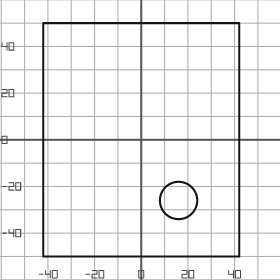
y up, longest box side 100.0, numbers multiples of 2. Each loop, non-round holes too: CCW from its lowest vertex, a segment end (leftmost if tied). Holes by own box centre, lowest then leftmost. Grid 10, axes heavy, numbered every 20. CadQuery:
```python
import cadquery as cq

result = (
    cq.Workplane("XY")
    .moveTo(-42.0, -50.0)
    .lineTo(42.0, -50.0)
    .lineTo(42.0, 50.0)
    .lineTo(-42.0, 50.0)
    .close()
    .moveTo(16.0, -26.0)
    .circle(8.0)
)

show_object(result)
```